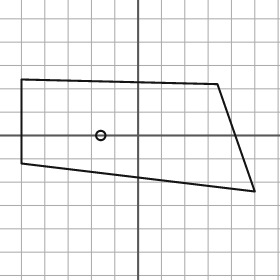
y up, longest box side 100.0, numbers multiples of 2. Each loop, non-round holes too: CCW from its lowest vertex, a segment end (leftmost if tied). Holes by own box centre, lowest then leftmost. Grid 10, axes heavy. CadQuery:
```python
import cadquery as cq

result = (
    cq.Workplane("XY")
    .moveTo(50.0, -24.0)
    .lineTo(34.0, 22.0)
    .lineTo(-50.0, 24.0)
    .lineTo(-50.0, -12.0)
    .close()
    .moveTo(-16.0, 0.0)
    .circle(2.0)
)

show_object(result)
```